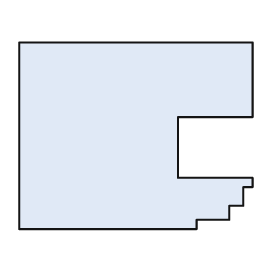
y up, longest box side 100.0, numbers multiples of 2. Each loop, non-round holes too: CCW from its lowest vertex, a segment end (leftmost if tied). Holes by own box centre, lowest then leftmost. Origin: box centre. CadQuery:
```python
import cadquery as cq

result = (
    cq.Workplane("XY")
    .moveTo(-50.0, -40.0)
    .lineTo(26.0, -40.0)
    .lineTo(26.0, -36.0)
    .lineTo(40.0, -36.0)
    .lineTo(40.0, -30.0)
    .lineTo(46.0, -30.0)
    .lineTo(46.0, -22.0)
    .lineTo(50.0, -22.0)
    .lineTo(50.0, -18.0)
    .lineTo(18.0, -18.0)
    .lineTo(18.0, 8.0)
    .lineTo(50.0, 8.0)
    .lineTo(50.0, 40.0)
    .lineTo(-50.0, 40.0)
    .close()
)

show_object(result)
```